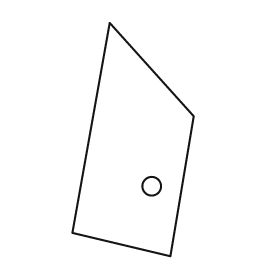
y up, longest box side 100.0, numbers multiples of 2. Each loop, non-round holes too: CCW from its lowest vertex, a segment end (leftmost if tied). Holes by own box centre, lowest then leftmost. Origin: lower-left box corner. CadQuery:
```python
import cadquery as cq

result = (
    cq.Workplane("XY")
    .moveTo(42.0, 0.0)
    .lineTo(52.0, 60.0)
    .lineTo(16.0, 100.0)
    .lineTo(0.0, 10.0)
    .close()
    .moveTo(34.0, 30.0)
    .circle(4.0)
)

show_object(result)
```